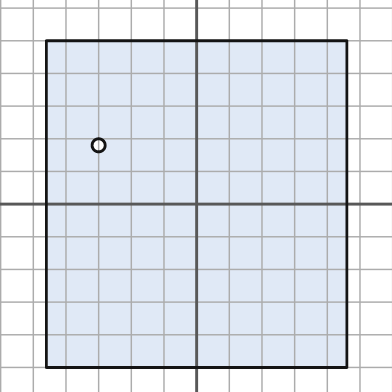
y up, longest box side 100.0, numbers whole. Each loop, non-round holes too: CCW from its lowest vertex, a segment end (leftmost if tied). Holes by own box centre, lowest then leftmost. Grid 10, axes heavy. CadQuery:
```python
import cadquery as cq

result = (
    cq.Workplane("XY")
    .moveTo(-46.0, -50.0)
    .lineTo(46.0, -50.0)
    .lineTo(46.0, 50.0)
    .lineTo(-46.0, 50.0)
    .close()
    .moveTo(-30.0, 18.0)
    .circle(2.0)
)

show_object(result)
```